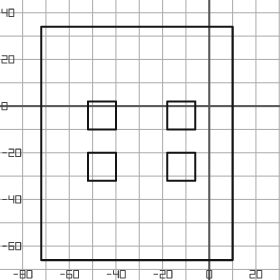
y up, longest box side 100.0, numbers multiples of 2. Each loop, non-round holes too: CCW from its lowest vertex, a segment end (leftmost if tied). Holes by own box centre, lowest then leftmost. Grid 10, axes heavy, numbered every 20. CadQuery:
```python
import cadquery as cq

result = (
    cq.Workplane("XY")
    .moveTo(-72.0, -66.0)
    .lineTo(10.0, -66.0)
    .lineTo(10.0, 34.0)
    .lineTo(-72.0, 34.0)
    .close()
    .moveTo(-52.0, -32.0)
    .lineTo(-40.0, -32.0)
    .lineTo(-40.0, -20.0)
    .lineTo(-52.0, -20.0)
    .close()
    .moveTo(-18.0, -32.0)
    .lineTo(-6.0, -32.0)
    .lineTo(-6.0, -20.0)
    .lineTo(-18.0, -20.0)
    .close()
    .moveTo(-52.0, -10.0)
    .lineTo(-40.0, -10.0)
    .lineTo(-40.0, 2.0)
    .lineTo(-52.0, 2.0)
    .close()
    .moveTo(-18.0, -10.0)
    .lineTo(-6.0, -10.0)
    .lineTo(-6.0, 2.0)
    .lineTo(-18.0, 2.0)
    .close()
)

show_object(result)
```